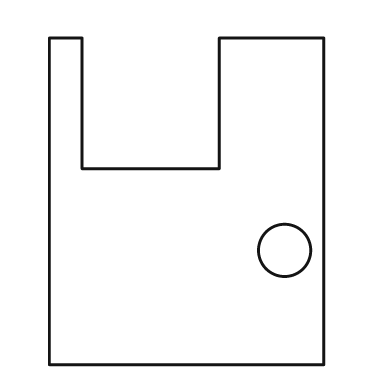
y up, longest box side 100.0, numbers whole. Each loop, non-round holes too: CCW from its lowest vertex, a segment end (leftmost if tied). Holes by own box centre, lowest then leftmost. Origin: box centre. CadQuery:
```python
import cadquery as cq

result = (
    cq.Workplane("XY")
    .moveTo(-42.0, -50.0)
    .lineTo(42.0, -50.0)
    .lineTo(42.0, 50.0)
    .lineTo(10.0, 50.0)
    .lineTo(10.0, 10.0)
    .lineTo(-32.0, 10.0)
    .lineTo(-32.0, 50.0)
    .lineTo(-42.0, 50.0)
    .close()
    .moveTo(30.0, -15.0)
    .circle(8.0)
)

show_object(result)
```